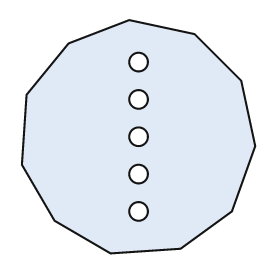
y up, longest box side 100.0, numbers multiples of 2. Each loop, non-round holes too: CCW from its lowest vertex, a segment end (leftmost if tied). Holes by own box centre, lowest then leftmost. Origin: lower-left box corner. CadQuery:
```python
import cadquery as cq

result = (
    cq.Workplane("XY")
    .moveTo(38.0, 0.0)
    .lineTo(68.0, 2.0)
    .lineTo(90.0, 18.0)
    .lineTo(100.0, 46.0)
    .lineTo(94.0, 74.0)
    .lineTo(74.0, 94.0)
    .lineTo(46.0, 100.0)
    .lineTo(20.0, 90.0)
    .lineTo(2.0, 68.0)
    .lineTo(0.0, 38.0)
    .lineTo(14.0, 14.0)
    .close()
    .moveTo(50.0, 18.0)
    .circle(4.0)
    .moveTo(50.0, 34.0)
    .circle(4.0)
    .moveTo(50.0, 50.0)
    .circle(4.0)
    .moveTo(50.0, 66.0)
    .circle(4.0)
    .moveTo(50.0, 82.0)
    .circle(4.0)
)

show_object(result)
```